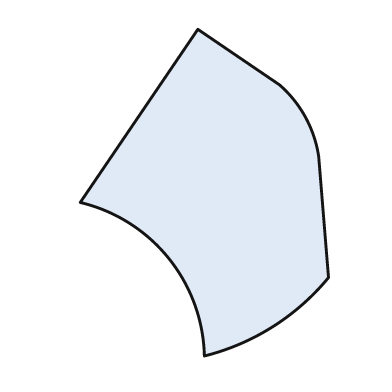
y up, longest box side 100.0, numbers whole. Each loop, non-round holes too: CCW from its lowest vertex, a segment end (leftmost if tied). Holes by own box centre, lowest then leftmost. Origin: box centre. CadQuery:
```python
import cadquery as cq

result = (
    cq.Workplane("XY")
    .moveTo(0.0, -50.0)
    .threePointArc((21.0, -41.0), (38.0, -26.0))
    .lineTo(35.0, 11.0)
    .threePointArc((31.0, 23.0), (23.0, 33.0))
    .lineTo(-2.0, 50.0)
    .lineTo(-38.0, -3.0)
    .threePointArc((-11.0, -20.0), (0.0, -50.0))
    .close()
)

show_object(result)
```